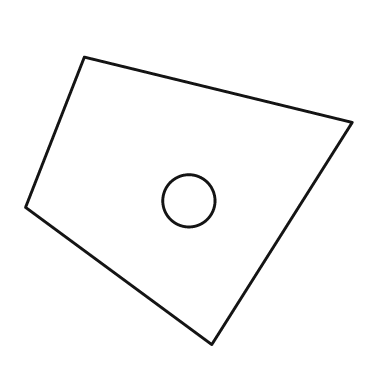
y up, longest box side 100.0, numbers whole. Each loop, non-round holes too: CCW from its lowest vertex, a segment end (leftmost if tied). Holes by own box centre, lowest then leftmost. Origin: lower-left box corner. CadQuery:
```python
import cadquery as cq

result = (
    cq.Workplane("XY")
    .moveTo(57.0, 0.0)
    .lineTo(100.0, 68.0)
    .lineTo(18.0, 88.0)
    .lineTo(0.0, 42.0)
    .close()
    .moveTo(50.0, 44.0)
    .circle(8.0)
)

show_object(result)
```